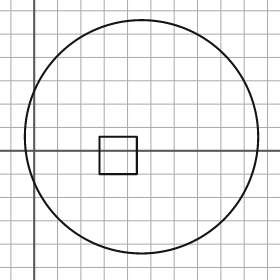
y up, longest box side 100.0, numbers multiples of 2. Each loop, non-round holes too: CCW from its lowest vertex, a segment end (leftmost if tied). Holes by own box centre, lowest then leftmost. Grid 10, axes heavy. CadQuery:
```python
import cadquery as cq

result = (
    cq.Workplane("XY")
    .moveTo(46.0, 6.0)
    .circle(50.0)
    .moveTo(28.0, -10.0)
    .lineTo(44.0, -10.0)
    .lineTo(44.0, 6.0)
    .lineTo(28.0, 6.0)
    .close()
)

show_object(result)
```